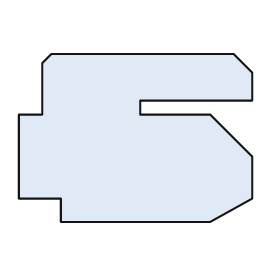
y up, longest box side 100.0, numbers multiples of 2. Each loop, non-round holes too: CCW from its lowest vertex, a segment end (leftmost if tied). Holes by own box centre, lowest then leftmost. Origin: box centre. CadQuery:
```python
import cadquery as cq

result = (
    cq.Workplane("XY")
    .moveTo(-32.0, -36.0)
    .lineTo(32.0, -36.0)
    .lineTo(50.0, -26.0)
    .lineTo(50.0, -8.0)
    .lineTo(32.0, 10.0)
    .lineTo(2.0, 10.0)
    .lineTo(2.0, 16.0)
    .lineTo(50.0, 16.0)
    .lineTo(50.0, 28.0)
    .lineTo(42.0, 36.0)
    .lineTo(-36.0, 36.0)
    .lineTo(-40.0, 32.0)
    .lineTo(-40.0, 10.0)
    .lineTo(-50.0, 10.0)
    .lineTo(-50.0, -26.0)
    .lineTo(-32.0, -26.0)
    .close()
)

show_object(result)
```